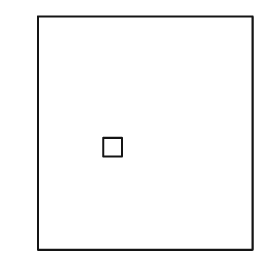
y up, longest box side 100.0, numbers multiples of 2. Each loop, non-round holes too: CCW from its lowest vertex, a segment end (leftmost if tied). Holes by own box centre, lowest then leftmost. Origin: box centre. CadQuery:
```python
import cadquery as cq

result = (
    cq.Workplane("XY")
    .moveTo(-46.0, -50.0)
    .lineTo(46.0, -50.0)
    .lineTo(46.0, 50.0)
    .lineTo(-46.0, 50.0)
    .close()
    .moveTo(-18.0, -10.0)
    .lineTo(-10.0, -10.0)
    .lineTo(-10.0, -2.0)
    .lineTo(-18.0, -2.0)
    .close()
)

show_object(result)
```